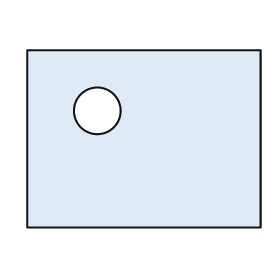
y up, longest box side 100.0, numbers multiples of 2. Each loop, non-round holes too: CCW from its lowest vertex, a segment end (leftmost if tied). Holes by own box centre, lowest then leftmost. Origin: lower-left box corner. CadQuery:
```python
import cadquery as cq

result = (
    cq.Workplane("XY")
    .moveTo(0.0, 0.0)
    .lineTo(100.0, 0.0)
    .lineTo(100.0, 76.0)
    .lineTo(0.0, 76.0)
    .close()
    .moveTo(30.0, 50.0)
    .circle(10.0)
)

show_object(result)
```